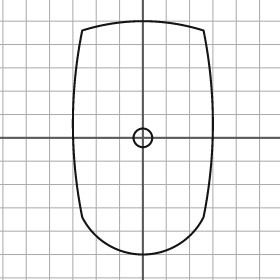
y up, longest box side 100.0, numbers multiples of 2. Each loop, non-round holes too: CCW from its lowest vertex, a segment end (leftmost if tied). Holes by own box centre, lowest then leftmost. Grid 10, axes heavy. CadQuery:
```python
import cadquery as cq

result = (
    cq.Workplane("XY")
    .moveTo(-26.0, -34.0)
    .threePointArc((0.0, -50.0), (26.0, -34.0))
    .threePointArc((30.0, 6.0), (26.0, 46.0))
    .threePointArc((0.0, 50.0), (-26.0, 46.0))
    .threePointArc((-30.0, 6.0), (-26.0, -34.0))
    .close()
    .moveTo(0.0, 0.0)
    .circle(4.0)
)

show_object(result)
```